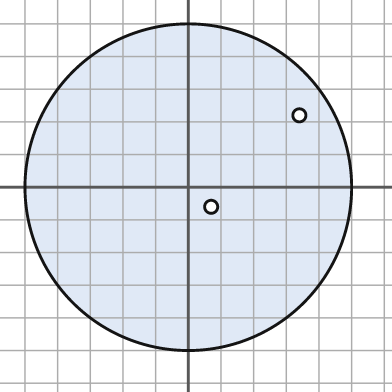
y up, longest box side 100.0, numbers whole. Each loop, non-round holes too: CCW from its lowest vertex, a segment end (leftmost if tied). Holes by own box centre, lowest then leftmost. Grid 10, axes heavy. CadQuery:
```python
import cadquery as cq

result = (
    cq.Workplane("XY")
    .moveTo(0.0, 0.0)
    .circle(50.0)
    .moveTo(7.0, -6.0)
    .circle(2.0)
    .moveTo(34.0, 22.0)
    .circle(2.0)
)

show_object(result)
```